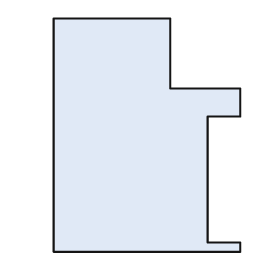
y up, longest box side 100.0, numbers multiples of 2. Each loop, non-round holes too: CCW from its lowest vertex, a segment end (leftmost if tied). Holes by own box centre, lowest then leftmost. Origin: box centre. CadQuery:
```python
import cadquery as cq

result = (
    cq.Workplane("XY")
    .moveTo(-40.0, -50.0)
    .lineTo(40.0, -50.0)
    .lineTo(40.0, -46.0)
    .lineTo(26.0, -46.0)
    .lineTo(26.0, 8.0)
    .lineTo(40.0, 8.0)
    .lineTo(40.0, 20.0)
    .lineTo(10.0, 20.0)
    .lineTo(10.0, 50.0)
    .lineTo(-40.0, 50.0)
    .close()
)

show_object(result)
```